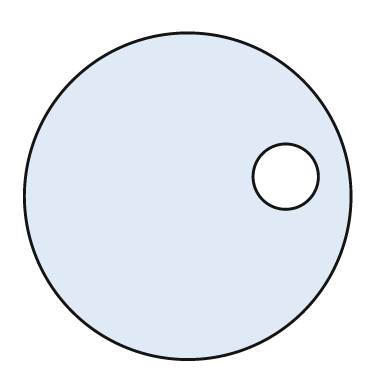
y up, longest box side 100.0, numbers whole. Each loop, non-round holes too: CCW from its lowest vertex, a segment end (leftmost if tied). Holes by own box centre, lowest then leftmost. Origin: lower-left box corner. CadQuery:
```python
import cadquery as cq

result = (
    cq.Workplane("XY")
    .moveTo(50.0, 50.0)
    .circle(50.0)
    .moveTo(80.0, 56.0)
    .circle(10.0)
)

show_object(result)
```